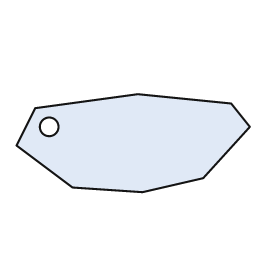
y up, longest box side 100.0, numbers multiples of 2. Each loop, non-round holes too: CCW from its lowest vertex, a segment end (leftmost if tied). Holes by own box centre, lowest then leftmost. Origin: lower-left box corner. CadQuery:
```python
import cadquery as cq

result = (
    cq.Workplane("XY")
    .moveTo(54.0, 0.0)
    .lineTo(80.0, 6.0)
    .lineTo(100.0, 28.0)
    .lineTo(92.0, 38.0)
    .lineTo(52.0, 42.0)
    .lineTo(8.0, 36.0)
    .lineTo(0.0, 20.0)
    .lineTo(24.0, 2.0)
    .close()
    .moveTo(14.0, 28.0)
    .circle(4.0)
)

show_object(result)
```